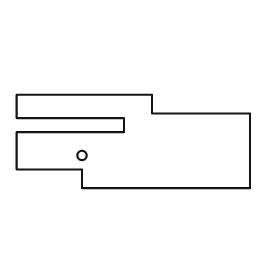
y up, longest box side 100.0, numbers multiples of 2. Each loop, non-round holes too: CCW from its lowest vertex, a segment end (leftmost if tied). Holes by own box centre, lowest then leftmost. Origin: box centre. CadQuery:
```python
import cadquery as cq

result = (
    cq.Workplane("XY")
    .moveTo(-22.0, -20.0)
    .lineTo(50.0, -20.0)
    .lineTo(50.0, 12.0)
    .lineTo(8.0, 12.0)
    .lineTo(8.0, 20.0)
    .lineTo(-50.0, 20.0)
    .lineTo(-50.0, 10.0)
    .lineTo(-4.0, 10.0)
    .lineTo(-4.0, 4.0)
    .lineTo(-50.0, 4.0)
    .lineTo(-50.0, -12.0)
    .lineTo(-22.0, -12.0)
    .close()
    .moveTo(-22.0, -6.0)
    .circle(2.0)
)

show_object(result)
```